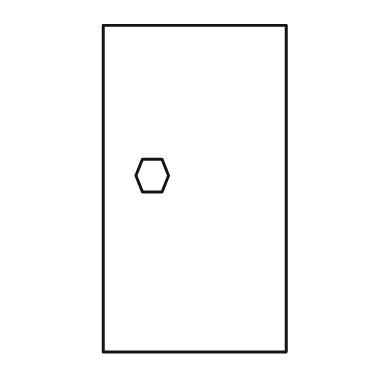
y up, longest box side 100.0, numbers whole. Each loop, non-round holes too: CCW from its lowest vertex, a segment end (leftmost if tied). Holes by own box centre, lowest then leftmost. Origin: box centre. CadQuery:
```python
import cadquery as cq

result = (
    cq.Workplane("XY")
    .moveTo(-28.0, -50.0)
    .lineTo(28.0, -50.0)
    .lineTo(28.0, 50.0)
    .lineTo(-28.0, 50.0)
    .close()
    .moveTo(-16.0, -1.0)
    .lineTo(-10.0, -1.0)
    .lineTo(-8.0, 4.0)
    .lineTo(-10.0, 9.0)
    .lineTo(-16.0, 9.0)
    .lineTo(-18.0, 4.0)
    .close()
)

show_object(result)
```